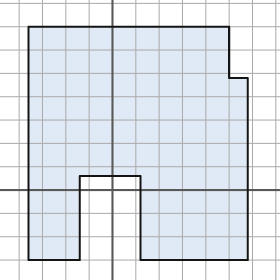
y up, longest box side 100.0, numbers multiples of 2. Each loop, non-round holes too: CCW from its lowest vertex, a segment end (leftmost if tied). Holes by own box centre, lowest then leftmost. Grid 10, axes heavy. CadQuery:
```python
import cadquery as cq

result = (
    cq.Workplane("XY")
    .moveTo(-36.0, -30.0)
    .lineTo(-14.0, -30.0)
    .lineTo(-14.0, 6.0)
    .lineTo(12.0, 6.0)
    .lineTo(12.0, -30.0)
    .lineTo(58.0, -30.0)
    .lineTo(58.0, 48.0)
    .lineTo(50.0, 48.0)
    .lineTo(50.0, 70.0)
    .lineTo(-36.0, 70.0)
    .close()
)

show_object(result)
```